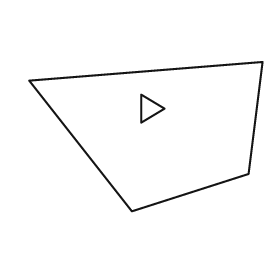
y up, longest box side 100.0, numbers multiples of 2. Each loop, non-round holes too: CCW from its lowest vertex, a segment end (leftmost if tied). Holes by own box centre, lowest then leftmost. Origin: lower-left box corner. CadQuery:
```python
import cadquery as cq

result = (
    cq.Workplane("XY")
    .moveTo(44.0, 0.0)
    .lineTo(94.0, 16.0)
    .lineTo(100.0, 64.0)
    .lineTo(0.0, 56.0)
    .close()
    .moveTo(48.0, 38.0)
    .lineTo(58.0, 44.0)
    .lineTo(48.0, 50.0)
    .close()
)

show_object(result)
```